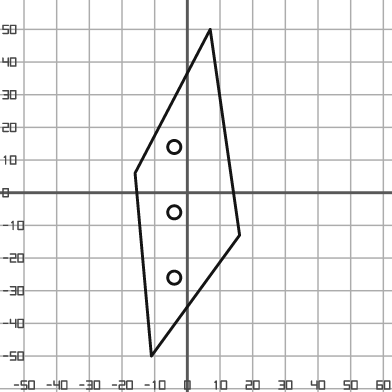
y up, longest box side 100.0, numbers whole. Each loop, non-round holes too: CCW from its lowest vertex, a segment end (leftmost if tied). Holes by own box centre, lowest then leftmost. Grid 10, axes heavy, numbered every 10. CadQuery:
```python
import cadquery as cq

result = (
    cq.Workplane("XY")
    .moveTo(-11.0, -50.0)
    .lineTo(16.0, -13.0)
    .lineTo(7.0, 50.0)
    .lineTo(-16.0, 6.0)
    .close()
    .moveTo(-4.0, -26.0)
    .circle(2.0)
    .moveTo(-4.0, -6.0)
    .circle(2.0)
    .moveTo(-4.0, 14.0)
    .circle(2.0)
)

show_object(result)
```